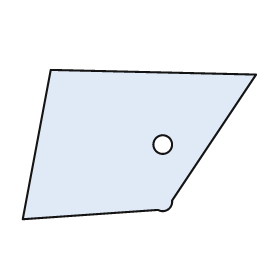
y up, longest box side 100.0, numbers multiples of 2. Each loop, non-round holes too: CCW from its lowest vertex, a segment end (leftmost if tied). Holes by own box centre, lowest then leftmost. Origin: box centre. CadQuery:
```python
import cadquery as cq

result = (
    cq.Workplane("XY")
    .moveTo(-50.0, -32.0)
    .lineTo(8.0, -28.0)
    .threePointArc((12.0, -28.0), (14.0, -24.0))
    .lineTo(50.0, 30.0)
    .lineTo(-38.0, 32.0)
    .close()
    .moveTo(10.0, 0.0)
    .circle(4.0)
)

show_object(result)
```